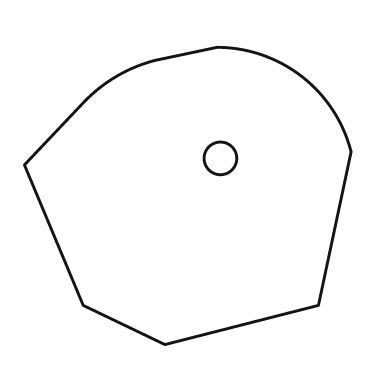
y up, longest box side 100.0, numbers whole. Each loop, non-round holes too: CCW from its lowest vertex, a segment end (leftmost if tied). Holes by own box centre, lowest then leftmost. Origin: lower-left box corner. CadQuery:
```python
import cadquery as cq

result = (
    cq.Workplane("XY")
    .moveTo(43.0, 0.0)
    .lineTo(90.0, 12.0)
    .lineTo(100.0, 59.0)
    .threePointArc((85.0, 82.0), (59.0, 91.0))
    .lineTo(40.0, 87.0)
    .threePointArc((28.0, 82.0), (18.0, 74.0))
    .lineTo(0.0, 55.0)
    .lineTo(18.0, 12.0)
    .close()
    .moveTo(60.0, 57.0)
    .circle(5.0)
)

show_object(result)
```